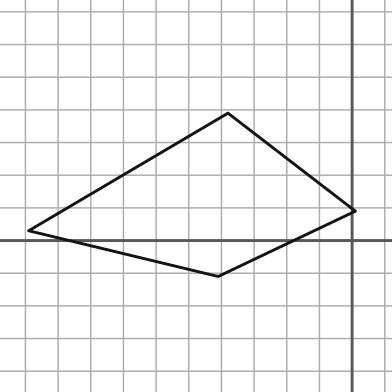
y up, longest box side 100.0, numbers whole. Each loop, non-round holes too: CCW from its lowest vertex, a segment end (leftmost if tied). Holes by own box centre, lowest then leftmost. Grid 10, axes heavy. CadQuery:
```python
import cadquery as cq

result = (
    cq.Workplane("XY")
    .moveTo(-41.0, -11.0)
    .lineTo(1.0, 9.0)
    .lineTo(-38.0, 39.0)
    .lineTo(-99.0, 3.0)
    .close()
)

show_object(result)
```